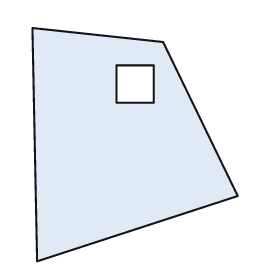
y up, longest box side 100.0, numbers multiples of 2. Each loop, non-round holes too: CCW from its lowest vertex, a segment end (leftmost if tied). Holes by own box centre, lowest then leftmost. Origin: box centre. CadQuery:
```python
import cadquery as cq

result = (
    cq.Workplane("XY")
    .moveTo(-42.0, -50.0)
    .lineTo(44.0, -22.0)
    .lineTo(12.0, 44.0)
    .lineTo(-44.0, 50.0)
    .close()
    .moveTo(-8.0, 18.0)
    .lineTo(8.0, 18.0)
    .lineTo(8.0, 34.0)
    .lineTo(-8.0, 34.0)
    .close()
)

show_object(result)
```